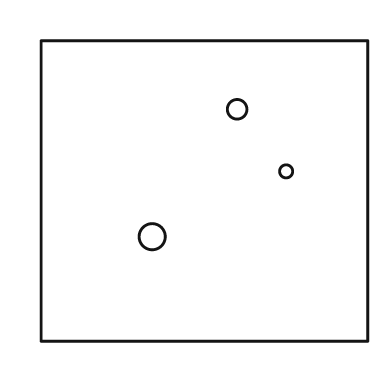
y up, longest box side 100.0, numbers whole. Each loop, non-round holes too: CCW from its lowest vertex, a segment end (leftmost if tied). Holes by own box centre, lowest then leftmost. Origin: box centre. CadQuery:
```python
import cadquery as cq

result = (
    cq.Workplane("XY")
    .moveTo(-50.0, -46.0)
    .lineTo(50.0, -46.0)
    .lineTo(50.0, 46.0)
    .lineTo(-50.0, 46.0)
    .close()
    .moveTo(-16.0, -14.0)
    .circle(4.0)
    .moveTo(25.0, 6.0)
    .circle(2.0)
    .moveTo(10.0, 25.0)
    .circle(3.0)
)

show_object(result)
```